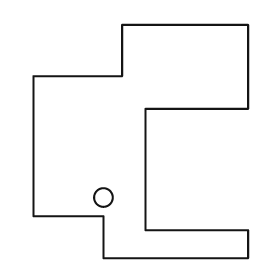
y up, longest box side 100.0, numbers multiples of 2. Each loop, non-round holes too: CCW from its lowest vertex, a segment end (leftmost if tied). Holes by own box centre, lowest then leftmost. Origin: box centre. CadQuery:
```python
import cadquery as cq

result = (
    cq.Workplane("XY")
    .moveTo(-16.0, -50.0)
    .lineTo(46.0, -50.0)
    .lineTo(46.0, -38.0)
    .lineTo(2.0, -38.0)
    .lineTo(2.0, 14.0)
    .lineTo(46.0, 14.0)
    .lineTo(46.0, 50.0)
    .lineTo(-8.0, 50.0)
    .lineTo(-8.0, 28.0)
    .lineTo(-46.0, 28.0)
    .lineTo(-46.0, -32.0)
    .lineTo(-16.0, -32.0)
    .close()
    .moveTo(-16.0, -24.0)
    .circle(4.0)
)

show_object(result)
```